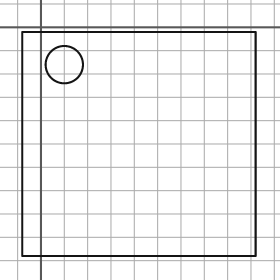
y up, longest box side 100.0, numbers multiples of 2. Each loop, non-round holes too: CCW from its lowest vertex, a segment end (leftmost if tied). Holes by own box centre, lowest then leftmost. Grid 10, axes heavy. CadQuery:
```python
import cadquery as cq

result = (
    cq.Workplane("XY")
    .moveTo(-8.0, -98.0)
    .lineTo(92.0, -98.0)
    .lineTo(92.0, -2.0)
    .lineTo(-8.0, -2.0)
    .close()
    .moveTo(10.0, -16.0)
    .circle(8.0)
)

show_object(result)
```